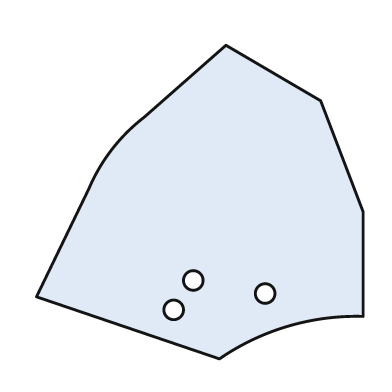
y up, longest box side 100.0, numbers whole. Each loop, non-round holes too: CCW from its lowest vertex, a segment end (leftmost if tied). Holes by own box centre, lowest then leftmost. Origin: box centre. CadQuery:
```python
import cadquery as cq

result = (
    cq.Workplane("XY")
    .moveTo(6.0, -48.0)
    .threePointArc((27.0, -38.0), (50.0, -35.0))
    .lineTo(50.0, -3.0)
    .lineTo(37.0, 31.0)
    .lineTo(8.0, 48.0)
    .lineTo(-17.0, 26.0)
    .threePointArc((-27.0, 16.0), (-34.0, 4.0))
    .lineTo(-50.0, -29.0)
    .close()
    .moveTo(-8.0, -33.0)
    .circle(3.0)
    .moveTo(20.0, -28.0)
    .circle(3.0)
    .moveTo(-2.0, -24.0)
    .circle(3.0)
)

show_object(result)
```